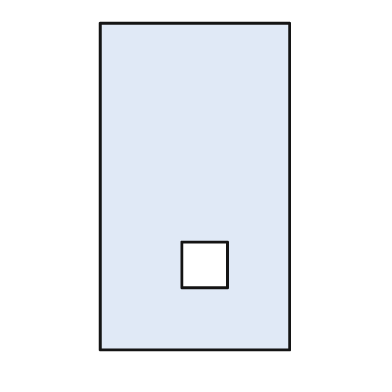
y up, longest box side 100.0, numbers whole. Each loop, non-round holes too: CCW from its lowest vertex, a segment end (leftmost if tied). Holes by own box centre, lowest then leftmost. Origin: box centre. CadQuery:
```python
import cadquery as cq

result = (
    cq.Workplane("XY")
    .moveTo(-29.0, -50.0)
    .lineTo(29.0, -50.0)
    .lineTo(29.0, 50.0)
    .lineTo(-29.0, 50.0)
    .close()
    .moveTo(-4.0, -31.0)
    .lineTo(10.0, -31.0)
    .lineTo(10.0, -17.0)
    .lineTo(-4.0, -17.0)
    .close()
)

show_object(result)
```